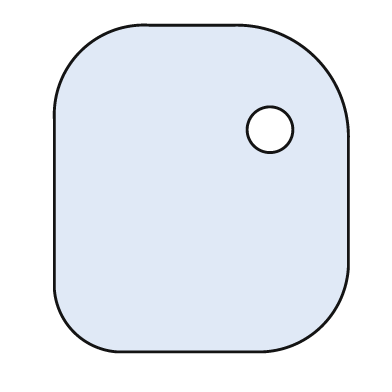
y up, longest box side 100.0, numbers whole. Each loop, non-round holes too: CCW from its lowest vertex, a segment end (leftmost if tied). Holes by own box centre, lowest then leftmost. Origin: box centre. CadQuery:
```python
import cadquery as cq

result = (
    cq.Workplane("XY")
    .moveTo(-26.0, -50.0)
    .lineTo(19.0, -50.0)
    .threePointArc((37.0, -42.0), (45.0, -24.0))
    .lineTo(45.0, 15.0)
    .threePointArc((35.0, 40.0), (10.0, 50.0))
    .lineTo(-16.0, 50.0)
    .threePointArc((-37.0, 42.0), (-45.0, 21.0))
    .lineTo(-45.0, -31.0)
    .threePointArc((-39.0, -44.0), (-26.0, -50.0))
    .close()
    .moveTo(21.0, 18.0)
    .circle(7.0)
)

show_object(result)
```